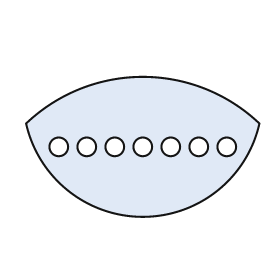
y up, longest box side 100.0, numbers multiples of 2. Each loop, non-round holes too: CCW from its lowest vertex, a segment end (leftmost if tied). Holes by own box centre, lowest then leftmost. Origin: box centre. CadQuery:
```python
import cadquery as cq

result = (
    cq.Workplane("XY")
    .moveTo(-50.0, 10.0)
    .threePointArc((0.0, -30.0), (50.0, 10.0))
    .threePointArc((0.0, 30.0), (-50.0, 10.0))
    .close()
    .moveTo(-36.0, 0.0)
    .circle(4.0)
    .moveTo(-24.0, 0.0)
    .circle(4.0)
    .moveTo(-12.0, 0.0)
    .circle(4.0)
    .moveTo(0.0, 0.0)
    .circle(4.0)
    .moveTo(12.0, 0.0)
    .circle(4.0)
    .moveTo(24.0, 0.0)
    .circle(4.0)
    .moveTo(36.0, 0.0)
    .circle(4.0)
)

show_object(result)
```